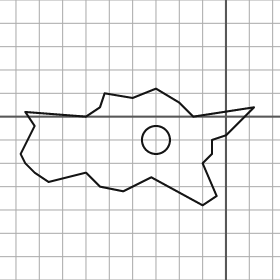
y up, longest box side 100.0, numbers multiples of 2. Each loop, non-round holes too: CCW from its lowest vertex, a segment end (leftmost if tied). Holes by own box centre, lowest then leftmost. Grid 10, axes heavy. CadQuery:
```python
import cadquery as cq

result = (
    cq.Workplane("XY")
    .moveTo(-10.0, -38.0)
    .lineTo(-4.0, -34.0)
    .lineTo(-10.0, -20.0)
    .lineTo(-6.0, -16.0)
    .lineTo(-6.0, -10.0)
    .lineTo(0.0, -8.0)
    .lineTo(12.0, 4.0)
    .lineTo(-14.0, 0.0)
    .lineTo(-20.0, 6.0)
    .lineTo(-30.0, 12.0)
    .lineTo(-40.0, 8.0)
    .lineTo(-52.0, 10.0)
    .lineTo(-54.0, 4.0)
    .lineTo(-60.0, 0.0)
    .lineTo(-86.0, 2.0)
    .lineTo(-82.0, -4.0)
    .lineTo(-88.0, -16.0)
    .lineTo(-86.0, -20.0)
    .lineTo(-82.0, -24.0)
    .lineTo(-76.0, -28.0)
    .lineTo(-60.0, -24.0)
    .lineTo(-54.0, -30.0)
    .lineTo(-44.0, -32.0)
    .lineTo(-32.0, -26.0)
    .close()
    .moveTo(-30.0, -10.0)
    .circle(6.0)
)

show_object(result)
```